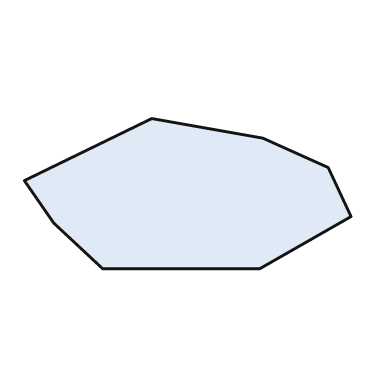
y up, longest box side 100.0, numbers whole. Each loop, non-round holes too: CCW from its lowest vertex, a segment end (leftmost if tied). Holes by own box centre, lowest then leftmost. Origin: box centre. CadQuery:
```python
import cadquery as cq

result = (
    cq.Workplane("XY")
    .moveTo(-26.0, -23.0)
    .lineTo(22.0, -23.0)
    .lineTo(50.0, -7.0)
    .lineTo(43.0, 8.0)
    .lineTo(23.0, 17.0)
    .lineTo(-11.0, 23.0)
    .lineTo(-50.0, 4.0)
    .lineTo(-41.0, -9.0)
    .close()
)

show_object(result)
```